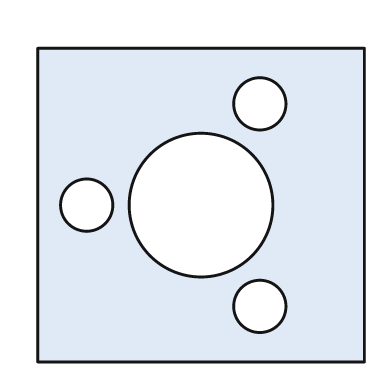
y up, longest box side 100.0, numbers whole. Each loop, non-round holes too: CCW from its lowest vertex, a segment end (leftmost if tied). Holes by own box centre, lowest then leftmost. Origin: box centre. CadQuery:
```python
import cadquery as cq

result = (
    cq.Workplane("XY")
    .moveTo(-50.0, -48.0)
    .lineTo(50.0, -48.0)
    .lineTo(50.0, 48.0)
    .lineTo(-50.0, 48.0)
    .close()
    .moveTo(18.0, -31.0)
    .circle(8.0)
    .moveTo(-35.0, 0.0)
    .circle(8.0)
    .moveTo(0.0, 0.0)
    .circle(22.0)
    .moveTo(18.0, 31.0)
    .circle(8.0)
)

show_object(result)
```